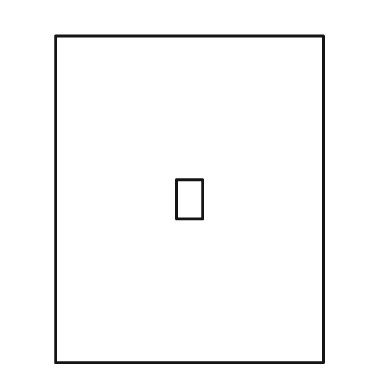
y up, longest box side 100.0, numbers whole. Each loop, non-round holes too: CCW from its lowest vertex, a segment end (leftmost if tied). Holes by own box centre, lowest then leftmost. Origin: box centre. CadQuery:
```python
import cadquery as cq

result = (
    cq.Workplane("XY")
    .moveTo(-41.0, -50.0)
    .lineTo(41.0, -50.0)
    .lineTo(41.0, 50.0)
    .lineTo(-41.0, 50.0)
    .close()
    .moveTo(-4.0, -6.0)
    .lineTo(4.0, -6.0)
    .lineTo(4.0, 6.0)
    .lineTo(-4.0, 6.0)
    .close()
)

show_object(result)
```